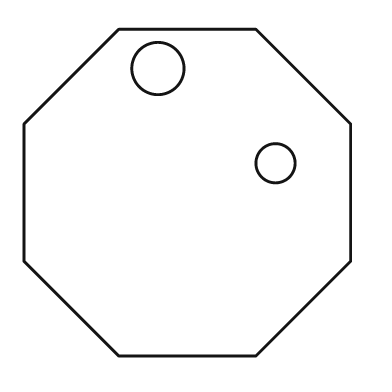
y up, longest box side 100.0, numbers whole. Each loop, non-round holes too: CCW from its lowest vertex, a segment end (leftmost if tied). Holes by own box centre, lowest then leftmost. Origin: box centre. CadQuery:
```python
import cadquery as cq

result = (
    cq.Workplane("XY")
    .moveTo(-21.0, -50.0)
    .lineTo(21.0, -50.0)
    .lineTo(50.0, -21.0)
    .lineTo(50.0, 21.0)
    .lineTo(21.0, 50.0)
    .lineTo(-21.0, 50.0)
    .lineTo(-50.0, 21.0)
    .lineTo(-50.0, -21.0)
    .close()
    .moveTo(27.0, 9.0)
    .circle(6.0)
    .moveTo(-9.0, 38.0)
    .circle(8.0)
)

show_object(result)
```